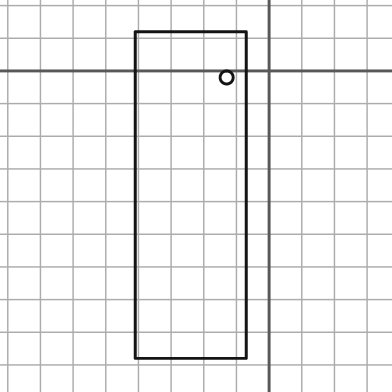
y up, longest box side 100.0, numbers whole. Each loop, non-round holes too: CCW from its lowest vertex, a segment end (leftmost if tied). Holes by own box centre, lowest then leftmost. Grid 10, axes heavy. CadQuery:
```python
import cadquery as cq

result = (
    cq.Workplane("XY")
    .moveTo(-41.0, -88.0)
    .lineTo(-7.0, -88.0)
    .lineTo(-7.0, 12.0)
    .lineTo(-41.0, 12.0)
    .close()
    .moveTo(-13.0, -2.0)
    .circle(2.0)
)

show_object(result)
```